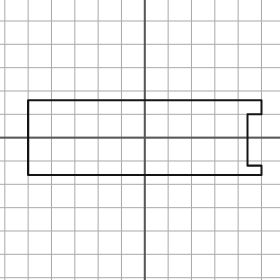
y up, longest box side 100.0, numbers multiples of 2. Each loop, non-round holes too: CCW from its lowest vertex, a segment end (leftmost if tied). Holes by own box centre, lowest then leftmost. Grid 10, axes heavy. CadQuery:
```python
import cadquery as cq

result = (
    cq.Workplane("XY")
    .moveTo(-50.0, -16.0)
    .lineTo(50.0, -16.0)
    .lineTo(50.0, -12.0)
    .lineTo(44.0, -12.0)
    .lineTo(44.0, 10.0)
    .lineTo(50.0, 10.0)
    .lineTo(50.0, 16.0)
    .lineTo(-50.0, 16.0)
    .close()
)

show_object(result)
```